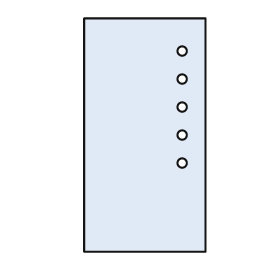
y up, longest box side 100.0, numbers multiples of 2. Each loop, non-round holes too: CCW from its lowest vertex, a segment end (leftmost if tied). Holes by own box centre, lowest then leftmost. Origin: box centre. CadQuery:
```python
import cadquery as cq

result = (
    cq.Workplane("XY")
    .moveTo(-26.0, -50.0)
    .lineTo(26.0, -50.0)
    .lineTo(26.0, 50.0)
    .lineTo(-26.0, 50.0)
    .close()
    .moveTo(16.0, -12.0)
    .circle(2.0)
    .moveTo(16.0, 0.0)
    .circle(2.0)
    .moveTo(16.0, 12.0)
    .circle(2.0)
    .moveTo(16.0, 24.0)
    .circle(2.0)
    .moveTo(16.0, 36.0)
    .circle(2.0)
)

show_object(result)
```